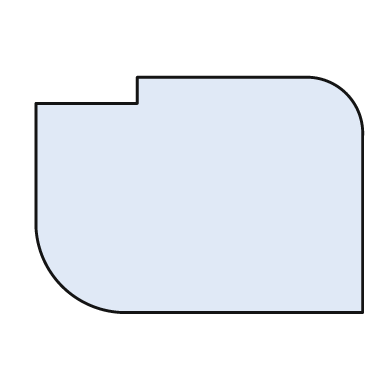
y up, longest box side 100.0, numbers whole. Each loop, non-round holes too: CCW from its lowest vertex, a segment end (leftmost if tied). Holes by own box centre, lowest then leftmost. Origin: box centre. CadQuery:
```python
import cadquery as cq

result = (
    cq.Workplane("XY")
    .moveTo(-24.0, -36.0)
    .lineTo(50.0, -36.0)
    .lineTo(50.0, 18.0)
    .threePointArc((45.0, 31.0), (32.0, 36.0))
    .lineTo(-19.0, 36.0)
    .lineTo(-19.0, 28.0)
    .lineTo(-50.0, 28.0)
    .lineTo(-50.0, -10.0)
    .threePointArc((-42.0, -28.0), (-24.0, -36.0))
    .close()
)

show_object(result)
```